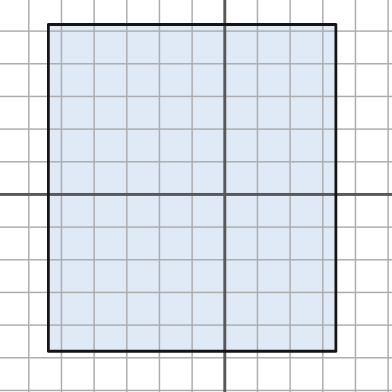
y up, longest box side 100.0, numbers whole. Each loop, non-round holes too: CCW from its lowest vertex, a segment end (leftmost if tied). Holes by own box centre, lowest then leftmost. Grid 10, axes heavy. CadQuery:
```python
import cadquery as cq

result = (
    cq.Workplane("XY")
    .moveTo(-54.0, -48.0)
    .lineTo(34.0, -48.0)
    .lineTo(34.0, 52.0)
    .lineTo(-54.0, 52.0)
    .close()
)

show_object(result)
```